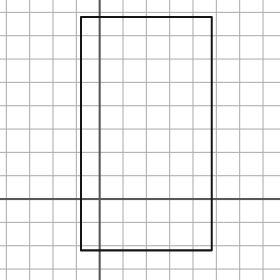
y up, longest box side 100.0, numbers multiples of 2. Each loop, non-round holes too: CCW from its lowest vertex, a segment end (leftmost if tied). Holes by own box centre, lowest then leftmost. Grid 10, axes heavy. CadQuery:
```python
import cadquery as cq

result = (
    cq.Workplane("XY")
    .moveTo(-8.0, -22.0)
    .lineTo(48.0, -22.0)
    .lineTo(48.0, 78.0)
    .lineTo(-8.0, 78.0)
    .close()
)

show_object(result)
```